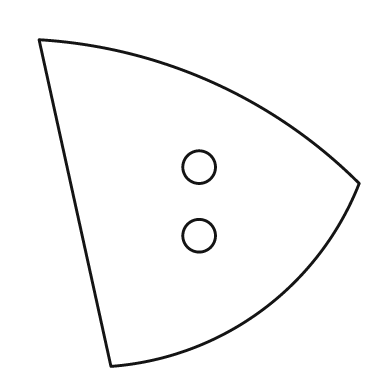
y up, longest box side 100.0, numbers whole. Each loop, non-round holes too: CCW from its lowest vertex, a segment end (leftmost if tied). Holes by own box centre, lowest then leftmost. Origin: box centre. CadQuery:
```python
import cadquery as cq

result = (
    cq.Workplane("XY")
    .moveTo(-27.0, -50.0)
    .threePointArc((19.0, -33.0), (49.0, 6.0))
    .threePointArc((4.0, 37.0), (-49.0, 50.0))
    .close()
    .moveTo(0.0, -10.0)
    .circle(5.0)
    .moveTo(0.0, 11.0)
    .circle(5.0)
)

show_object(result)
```